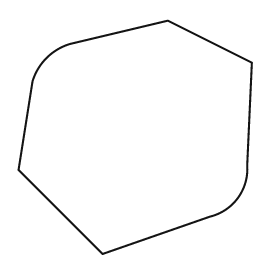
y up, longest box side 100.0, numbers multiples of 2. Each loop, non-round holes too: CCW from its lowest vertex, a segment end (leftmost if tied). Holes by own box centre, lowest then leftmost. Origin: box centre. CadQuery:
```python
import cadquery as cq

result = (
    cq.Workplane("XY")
    .moveTo(-14.0, -50.0)
    .lineTo(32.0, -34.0)
    .threePointArc((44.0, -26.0), (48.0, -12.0))
    .lineTo(50.0, 32.0)
    .lineTo(14.0, 50.0)
    .lineTo(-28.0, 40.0)
    .threePointArc((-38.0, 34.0), (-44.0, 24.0))
    .lineTo(-50.0, -14.0)
    .close()
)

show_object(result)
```